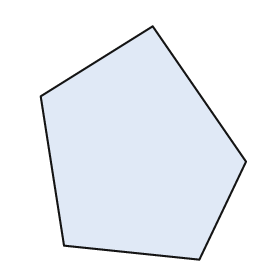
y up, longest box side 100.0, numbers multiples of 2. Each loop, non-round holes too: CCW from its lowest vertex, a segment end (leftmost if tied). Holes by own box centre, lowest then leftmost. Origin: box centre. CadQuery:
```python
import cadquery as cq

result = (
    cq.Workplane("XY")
    .moveTo(24.0, -50.0)
    .lineTo(44.0, -8.0)
    .lineTo(4.0, 50.0)
    .lineTo(-44.0, 20.0)
    .lineTo(-34.0, -44.0)
    .close()
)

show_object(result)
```